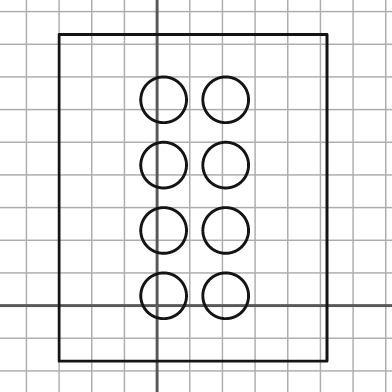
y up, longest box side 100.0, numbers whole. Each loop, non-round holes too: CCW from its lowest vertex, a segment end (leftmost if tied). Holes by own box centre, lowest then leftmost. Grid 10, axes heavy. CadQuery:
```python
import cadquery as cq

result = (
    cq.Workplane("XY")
    .moveTo(-30.0, -17.0)
    .lineTo(52.0, -17.0)
    .lineTo(52.0, 83.0)
    .lineTo(-30.0, 83.0)
    .close()
    .moveTo(2.0, 3.0)
    .circle(7.0)
    .moveTo(21.0, 3.0)
    .circle(7.0)
    .moveTo(2.0, 23.0)
    .circle(7.0)
    .moveTo(21.0, 23.0)
    .circle(7.0)
    .moveTo(2.0, 43.0)
    .circle(7.0)
    .moveTo(21.0, 43.0)
    .circle(7.0)
    .moveTo(2.0, 63.0)
    .circle(7.0)
    .moveTo(21.0, 63.0)
    .circle(7.0)
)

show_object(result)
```